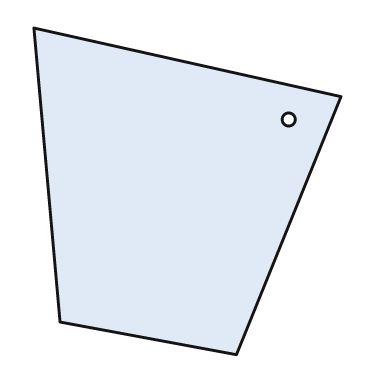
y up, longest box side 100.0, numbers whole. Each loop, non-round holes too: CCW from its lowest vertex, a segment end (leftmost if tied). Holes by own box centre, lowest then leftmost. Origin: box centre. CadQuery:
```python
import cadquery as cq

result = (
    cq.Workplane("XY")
    .moveTo(15.0, -50.0)
    .lineTo(47.0, 29.0)
    .lineTo(-47.0, 50.0)
    .lineTo(-39.0, -40.0)
    .close()
    .moveTo(31.0, 22.0)
    .circle(2.0)
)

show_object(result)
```